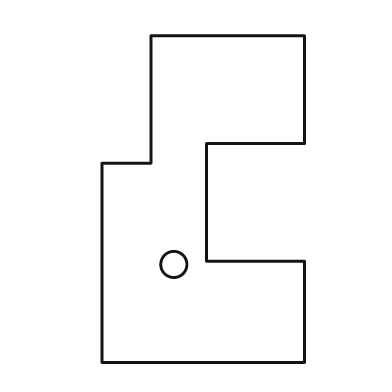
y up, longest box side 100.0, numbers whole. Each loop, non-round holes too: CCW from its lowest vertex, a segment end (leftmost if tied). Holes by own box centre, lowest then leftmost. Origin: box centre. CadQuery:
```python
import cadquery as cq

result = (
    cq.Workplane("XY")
    .moveTo(-31.0, -50.0)
    .lineTo(31.0, -50.0)
    .lineTo(31.0, -19.0)
    .lineTo(1.0, -19.0)
    .lineTo(1.0, 17.0)
    .lineTo(31.0, 17.0)
    .lineTo(31.0, 50.0)
    .lineTo(-16.0, 50.0)
    .lineTo(-16.0, 11.0)
    .lineTo(-31.0, 11.0)
    .close()
    .moveTo(-9.0, -20.0)
    .circle(4.0)
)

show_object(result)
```